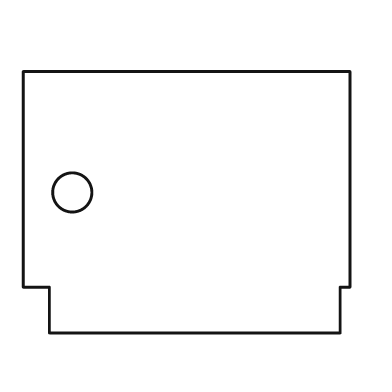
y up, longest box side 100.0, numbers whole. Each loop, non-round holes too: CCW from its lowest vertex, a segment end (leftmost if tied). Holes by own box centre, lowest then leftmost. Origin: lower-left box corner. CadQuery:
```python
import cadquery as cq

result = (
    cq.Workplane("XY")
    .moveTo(8.0, 0.0)
    .lineTo(97.0, 0.0)
    .lineTo(97.0, 14.0)
    .lineTo(100.0, 14.0)
    .lineTo(100.0, 80.0)
    .lineTo(0.0, 80.0)
    .lineTo(0.0, 14.0)
    .lineTo(8.0, 14.0)
    .close()
    .moveTo(15.0, 43.0)
    .circle(6.0)
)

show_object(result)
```